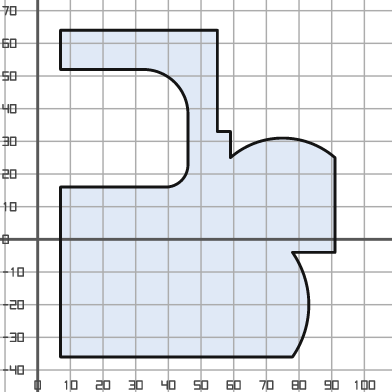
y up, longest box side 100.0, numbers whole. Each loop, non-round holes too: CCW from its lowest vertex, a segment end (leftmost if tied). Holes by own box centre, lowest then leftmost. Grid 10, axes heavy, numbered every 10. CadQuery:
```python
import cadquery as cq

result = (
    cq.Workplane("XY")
    .moveTo(7.0, -36.0)
    .lineTo(78.0, -36.0)
    .threePointArc((83.0, -20.0), (78.0, -4.0))
    .lineTo(91.0, -4.0)
    .lineTo(91.0, 25.0)
    .threePointArc((75.0, 31.0), (59.0, 25.0))
    .lineTo(59.0, 33.0)
    .lineTo(55.0, 33.0)
    .lineTo(55.0, 64.0)
    .lineTo(7.0, 64.0)
    .lineTo(7.0, 52.0)
    .lineTo(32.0, 52.0)
    .threePointArc((42.0, 48.0), (46.0, 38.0))
    .lineTo(46.0, 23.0)
    .threePointArc((44.0, 18.0), (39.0, 16.0))
    .lineTo(7.0, 16.0)
    .close()
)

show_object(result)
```